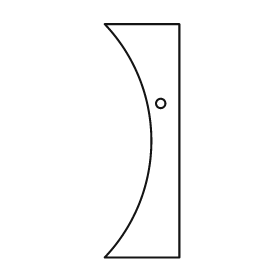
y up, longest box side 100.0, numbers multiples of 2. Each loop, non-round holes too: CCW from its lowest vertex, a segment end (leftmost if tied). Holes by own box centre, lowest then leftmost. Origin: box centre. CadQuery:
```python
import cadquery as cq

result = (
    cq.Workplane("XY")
    .moveTo(-16.0, -50.0)
    .lineTo(16.0, -50.0)
    .lineTo(16.0, 50.0)
    .lineTo(-16.0, 50.0)
    .threePointArc((4.0, 0.0), (-16.0, -50.0))
    .close()
    .moveTo(8.0, 16.0)
    .circle(2.0)
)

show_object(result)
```